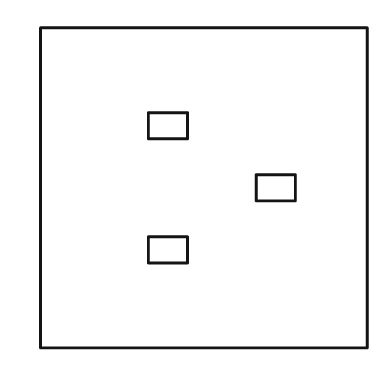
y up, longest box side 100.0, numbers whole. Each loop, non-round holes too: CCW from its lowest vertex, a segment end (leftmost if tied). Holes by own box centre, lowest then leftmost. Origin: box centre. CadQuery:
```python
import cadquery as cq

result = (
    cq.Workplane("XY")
    .moveTo(-50.0, -49.0)
    .lineTo(50.0, -49.0)
    .lineTo(50.0, 49.0)
    .lineTo(-50.0, 49.0)
    .close()
    .moveTo(-17.0, -23.0)
    .lineTo(-5.0, -23.0)
    .lineTo(-5.0, -15.0)
    .lineTo(-17.0, -15.0)
    .close()
    .moveTo(16.0, -4.0)
    .lineTo(28.0, -4.0)
    .lineTo(28.0, 4.0)
    .lineTo(16.0, 4.0)
    .close()
    .moveTo(-17.0, 15.0)
    .lineTo(-5.0, 15.0)
    .lineTo(-5.0, 23.0)
    .lineTo(-17.0, 23.0)
    .close()
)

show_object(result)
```